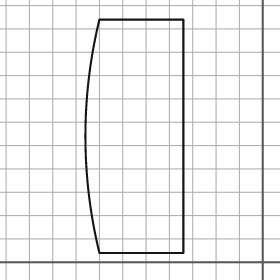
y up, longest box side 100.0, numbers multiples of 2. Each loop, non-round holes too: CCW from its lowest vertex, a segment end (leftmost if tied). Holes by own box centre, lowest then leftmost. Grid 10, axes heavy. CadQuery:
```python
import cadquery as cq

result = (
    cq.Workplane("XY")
    .moveTo(-70.0, 4.0)
    .lineTo(-34.0, 4.0)
    .lineTo(-34.0, 104.0)
    .lineTo(-70.0, 104.0)
    .threePointArc((-76.0, 54.0), (-70.0, 4.0))
    .close()
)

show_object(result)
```